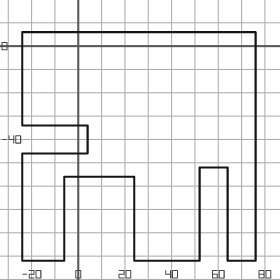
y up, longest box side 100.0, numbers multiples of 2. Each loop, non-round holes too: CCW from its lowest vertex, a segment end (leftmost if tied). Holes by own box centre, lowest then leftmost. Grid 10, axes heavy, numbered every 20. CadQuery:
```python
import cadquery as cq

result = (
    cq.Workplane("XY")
    .moveTo(-24.0, -92.0)
    .lineTo(-6.0, -92.0)
    .lineTo(-6.0, -56.0)
    .lineTo(24.0, -56.0)
    .lineTo(24.0, -92.0)
    .lineTo(52.0, -92.0)
    .lineTo(52.0, -52.0)
    .lineTo(64.0, -52.0)
    .lineTo(64.0, -92.0)
    .lineTo(76.0, -92.0)
    .lineTo(76.0, 6.0)
    .lineTo(-24.0, 6.0)
    .lineTo(-24.0, -34.0)
    .lineTo(4.0, -34.0)
    .lineTo(4.0, -46.0)
    .lineTo(-24.0, -46.0)
    .close()
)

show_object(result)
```